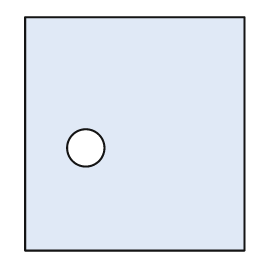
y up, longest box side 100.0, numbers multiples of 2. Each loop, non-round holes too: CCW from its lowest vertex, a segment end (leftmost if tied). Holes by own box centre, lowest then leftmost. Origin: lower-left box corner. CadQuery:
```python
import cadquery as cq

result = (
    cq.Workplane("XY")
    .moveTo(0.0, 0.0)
    .lineTo(94.0, 0.0)
    .lineTo(94.0, 100.0)
    .lineTo(0.0, 100.0)
    .close()
    .moveTo(26.0, 44.0)
    .circle(8.0)
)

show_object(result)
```